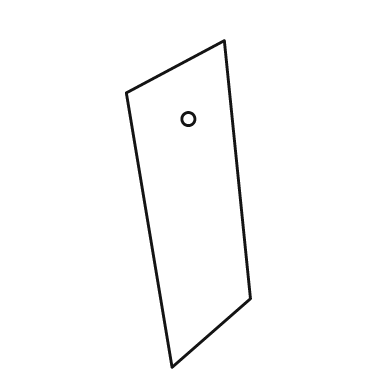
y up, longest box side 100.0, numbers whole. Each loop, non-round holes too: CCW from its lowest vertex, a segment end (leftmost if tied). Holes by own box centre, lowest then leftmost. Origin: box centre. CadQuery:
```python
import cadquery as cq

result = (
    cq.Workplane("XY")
    .moveTo(-5.0, -50.0)
    .lineTo(19.0, -29.0)
    .lineTo(11.0, 50.0)
    .lineTo(-19.0, 34.0)
    .close()
    .moveTo(0.0, 26.0)
    .circle(2.0)
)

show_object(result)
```